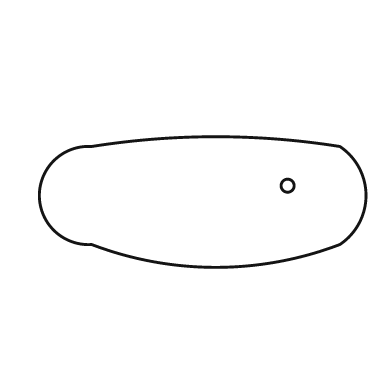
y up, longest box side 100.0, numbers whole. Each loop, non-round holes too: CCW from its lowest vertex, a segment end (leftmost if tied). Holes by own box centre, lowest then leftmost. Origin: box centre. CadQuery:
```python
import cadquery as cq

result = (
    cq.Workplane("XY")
    .moveTo(-34.0, -13.0)
    .threePointArc((4.0, -20.0), (42.0, -13.0))
    .threePointArc((50.0, 2.0), (42.0, 17.0))
    .threePointArc((4.0, 20.0), (-34.0, 17.0))
    .threePointArc((-50.0, 2.0), (-34.0, -13.0))
    .close()
    .moveTo(26.0, 5.0)
    .circle(2.0)
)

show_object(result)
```